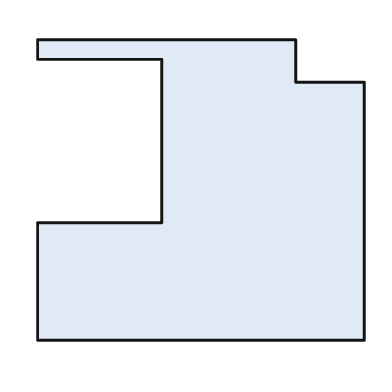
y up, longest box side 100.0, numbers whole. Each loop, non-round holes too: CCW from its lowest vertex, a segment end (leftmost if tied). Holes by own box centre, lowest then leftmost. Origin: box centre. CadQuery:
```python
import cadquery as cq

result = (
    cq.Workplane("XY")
    .moveTo(-50.0, -46.0)
    .lineTo(50.0, -46.0)
    .lineTo(50.0, 33.0)
    .lineTo(29.0, 33.0)
    .lineTo(29.0, 46.0)
    .lineTo(-50.0, 46.0)
    .lineTo(-50.0, 40.0)
    .lineTo(-12.0, 40.0)
    .lineTo(-12.0, -10.0)
    .lineTo(-50.0, -10.0)
    .close()
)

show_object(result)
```